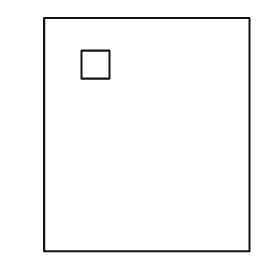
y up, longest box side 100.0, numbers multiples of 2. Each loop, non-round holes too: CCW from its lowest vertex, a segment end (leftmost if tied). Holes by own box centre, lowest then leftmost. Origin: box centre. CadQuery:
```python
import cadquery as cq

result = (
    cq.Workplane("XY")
    .moveTo(-44.0, -50.0)
    .lineTo(44.0, -50.0)
    .lineTo(44.0, 50.0)
    .lineTo(-44.0, 50.0)
    .close()
    .moveTo(-28.0, 24.0)
    .lineTo(-16.0, 24.0)
    .lineTo(-16.0, 36.0)
    .lineTo(-28.0, 36.0)
    .close()
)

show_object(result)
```